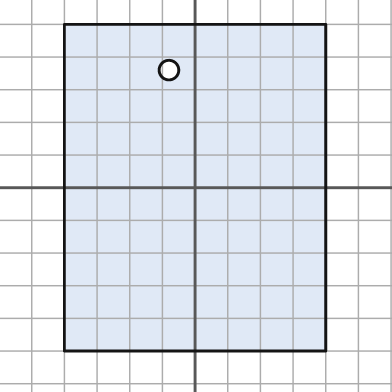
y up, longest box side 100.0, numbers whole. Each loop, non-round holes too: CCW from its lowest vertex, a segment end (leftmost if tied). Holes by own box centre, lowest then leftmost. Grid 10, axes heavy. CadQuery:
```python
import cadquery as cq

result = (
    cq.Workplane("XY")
    .moveTo(-40.0, -50.0)
    .lineTo(40.0, -50.0)
    .lineTo(40.0, 50.0)
    .lineTo(-40.0, 50.0)
    .close()
    .moveTo(-8.0, 36.0)
    .circle(3.0)
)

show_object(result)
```